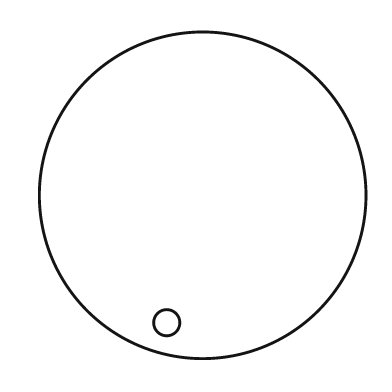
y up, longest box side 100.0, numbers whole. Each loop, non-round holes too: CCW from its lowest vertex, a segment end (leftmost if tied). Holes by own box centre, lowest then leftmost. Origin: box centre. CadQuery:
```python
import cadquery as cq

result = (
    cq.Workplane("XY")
    .moveTo(0.0, 0.0)
    .circle(50.0)
    .moveTo(-11.0, -39.0)
    .circle(4.0)
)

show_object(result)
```